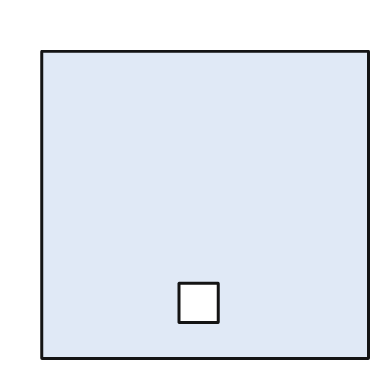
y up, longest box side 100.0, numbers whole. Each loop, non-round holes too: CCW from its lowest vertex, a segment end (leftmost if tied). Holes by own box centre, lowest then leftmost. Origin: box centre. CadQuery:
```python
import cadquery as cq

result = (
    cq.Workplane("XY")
    .moveTo(-50.0, -47.0)
    .lineTo(50.0, -47.0)
    .lineTo(50.0, 47.0)
    .lineTo(-50.0, 47.0)
    .close()
    .moveTo(-8.0, -36.0)
    .lineTo(4.0, -36.0)
    .lineTo(4.0, -24.0)
    .lineTo(-8.0, -24.0)
    .close()
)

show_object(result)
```